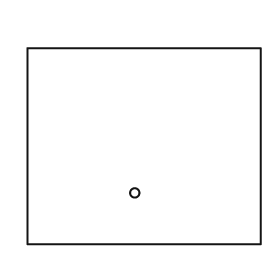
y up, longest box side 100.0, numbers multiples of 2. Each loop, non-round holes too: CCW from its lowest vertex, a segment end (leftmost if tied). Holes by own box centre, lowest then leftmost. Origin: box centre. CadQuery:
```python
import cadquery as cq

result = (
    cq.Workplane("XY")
    .moveTo(-50.0, -42.0)
    .lineTo(50.0, -42.0)
    .lineTo(50.0, 42.0)
    .lineTo(-50.0, 42.0)
    .close()
    .moveTo(-4.0, -20.0)
    .circle(2.0)
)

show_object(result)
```